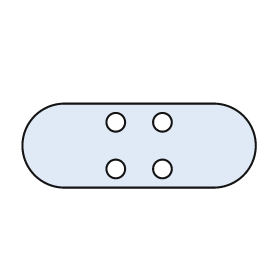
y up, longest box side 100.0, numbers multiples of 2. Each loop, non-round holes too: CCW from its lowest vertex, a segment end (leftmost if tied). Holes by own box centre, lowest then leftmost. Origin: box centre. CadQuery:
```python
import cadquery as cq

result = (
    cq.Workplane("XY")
    .moveTo(-32.0, -18.0)
    .lineTo(32.0, -18.0)
    .threePointArc((50.0, 0.0), (32.0, 18.0))
    .lineTo(-32.0, 18.0)
    .threePointArc((-50.0, 0.0), (-32.0, -18.0))
    .close()
    .moveTo(-10.0, -10.0)
    .circle(4.0)
    .moveTo(10.0, -10.0)
    .circle(4.0)
    .moveTo(-10.0, 10.0)
    .circle(4.0)
    .moveTo(10.0, 10.0)
    .circle(4.0)
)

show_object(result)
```